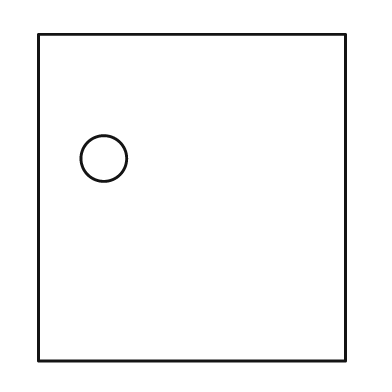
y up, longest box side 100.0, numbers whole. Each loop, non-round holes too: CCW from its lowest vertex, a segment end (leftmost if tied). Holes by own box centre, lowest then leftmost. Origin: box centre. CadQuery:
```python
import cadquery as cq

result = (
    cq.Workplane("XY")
    .moveTo(-47.0, -50.0)
    .lineTo(47.0, -50.0)
    .lineTo(47.0, 50.0)
    .lineTo(-47.0, 50.0)
    .close()
    .moveTo(-27.0, 12.0)
    .circle(7.0)
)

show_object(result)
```